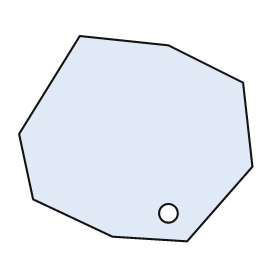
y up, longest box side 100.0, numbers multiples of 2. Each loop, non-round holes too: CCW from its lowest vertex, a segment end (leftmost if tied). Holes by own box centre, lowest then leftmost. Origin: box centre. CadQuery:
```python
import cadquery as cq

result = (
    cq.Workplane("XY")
    .moveTo(22.0, -44.0)
    .lineTo(50.0, -12.0)
    .lineTo(46.0, 24.0)
    .lineTo(14.0, 40.0)
    .lineTo(-24.0, 44.0)
    .lineTo(-50.0, 2.0)
    .lineTo(-44.0, -26.0)
    .lineTo(-10.0, -42.0)
    .close()
    .moveTo(14.0, -32.0)
    .circle(4.0)
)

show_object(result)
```